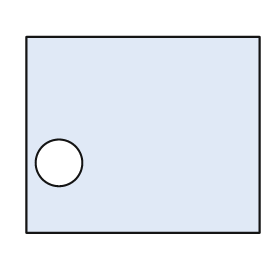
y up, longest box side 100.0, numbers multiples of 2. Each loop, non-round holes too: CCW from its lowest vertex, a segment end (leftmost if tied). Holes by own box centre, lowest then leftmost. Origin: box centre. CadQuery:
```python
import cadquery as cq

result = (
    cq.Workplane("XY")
    .moveTo(-50.0, -42.0)
    .lineTo(50.0, -42.0)
    .lineTo(50.0, 42.0)
    .lineTo(-50.0, 42.0)
    .close()
    .moveTo(-36.0, -12.0)
    .circle(10.0)
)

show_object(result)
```